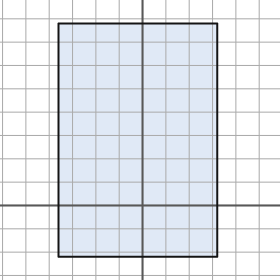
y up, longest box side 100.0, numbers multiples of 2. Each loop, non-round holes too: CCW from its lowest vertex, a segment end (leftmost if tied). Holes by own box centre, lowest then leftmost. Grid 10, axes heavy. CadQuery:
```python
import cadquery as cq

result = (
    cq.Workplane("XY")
    .moveTo(-36.0, -22.0)
    .lineTo(32.0, -22.0)
    .lineTo(32.0, 78.0)
    .lineTo(-36.0, 78.0)
    .close()
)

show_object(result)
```